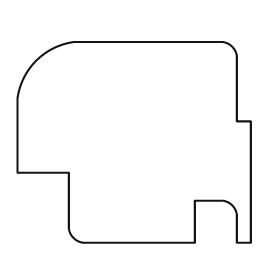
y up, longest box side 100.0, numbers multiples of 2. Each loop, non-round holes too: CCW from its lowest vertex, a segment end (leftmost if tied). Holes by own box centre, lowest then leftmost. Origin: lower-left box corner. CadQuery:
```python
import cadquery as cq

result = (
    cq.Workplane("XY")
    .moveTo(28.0, 0.0)
    .lineTo(76.0, 0.0)
    .lineTo(76.0, 18.0)
    .lineTo(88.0, 18.0)
    .threePointArc((92.0, 16.0), (94.0, 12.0))
    .lineTo(94.0, 0.0)
    .lineTo(100.0, 0.0)
    .lineTo(100.0, 52.0)
    .lineTo(94.0, 52.0)
    .lineTo(94.0, 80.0)
    .threePointArc((92.0, 84.0), (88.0, 86.0))
    .lineTo(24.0, 86.0)
    .threePointArc((8.0, 78.0), (0.0, 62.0))
    .lineTo(0.0, 30.0)
    .lineTo(22.0, 30.0)
    .lineTo(22.0, 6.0)
    .threePointArc((24.0, 2.0), (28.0, 0.0))
    .close()
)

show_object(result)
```